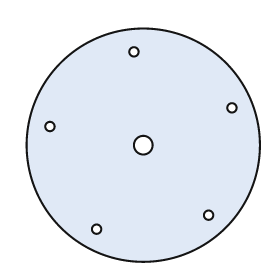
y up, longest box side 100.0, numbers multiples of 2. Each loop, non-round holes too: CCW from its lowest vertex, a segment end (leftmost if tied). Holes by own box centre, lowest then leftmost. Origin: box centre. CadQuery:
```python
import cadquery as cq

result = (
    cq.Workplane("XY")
    .moveTo(0.0, 0.0)
    .circle(50.0)
    .moveTo(-20.0, -36.0)
    .circle(2.0)
    .moveTo(28.0, -30.0)
    .circle(2.0)
    .moveTo(0.0, 0.0)
    .circle(4.0)
    .moveTo(-40.0, 8.0)
    .circle(2.0)
    .moveTo(38.0, 16.0)
    .circle(2.0)
    .moveTo(-4.0, 40.0)
    .circle(2.0)
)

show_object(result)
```